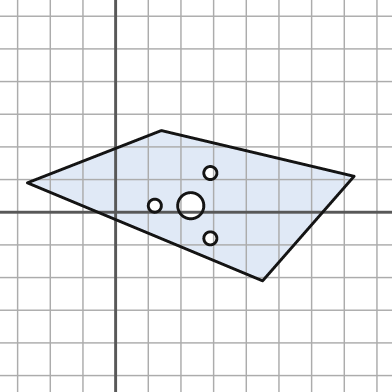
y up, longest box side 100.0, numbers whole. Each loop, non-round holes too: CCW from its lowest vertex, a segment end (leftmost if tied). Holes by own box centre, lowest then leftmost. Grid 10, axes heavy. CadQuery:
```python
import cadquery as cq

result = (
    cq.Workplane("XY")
    .moveTo(45.0, -21.0)
    .lineTo(73.0, 11.0)
    .lineTo(14.0, 25.0)
    .lineTo(-27.0, 9.0)
    .close()
    .moveTo(29.0, -8.0)
    .circle(2.0)
    .moveTo(12.0, 2.0)
    .circle(2.0)
    .moveTo(23.0, 2.0)
    .circle(4.0)
    .moveTo(29.0, 12.0)
    .circle(2.0)
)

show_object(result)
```